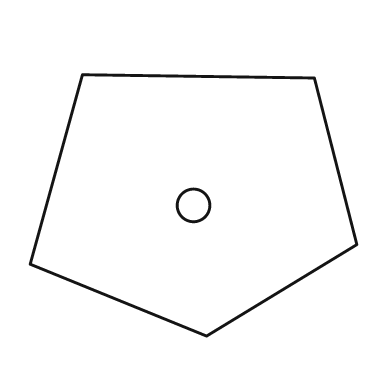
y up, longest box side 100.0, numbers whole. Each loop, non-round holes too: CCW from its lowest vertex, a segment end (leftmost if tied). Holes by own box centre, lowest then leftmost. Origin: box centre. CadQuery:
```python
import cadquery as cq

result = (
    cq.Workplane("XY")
    .moveTo(4.0, -40.0)
    .lineTo(50.0, -12.0)
    .lineTo(37.0, 39.0)
    .lineTo(-34.0, 40.0)
    .lineTo(-50.0, -18.0)
    .close()
    .moveTo(0.0, 0.0)
    .circle(5.0)
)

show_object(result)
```